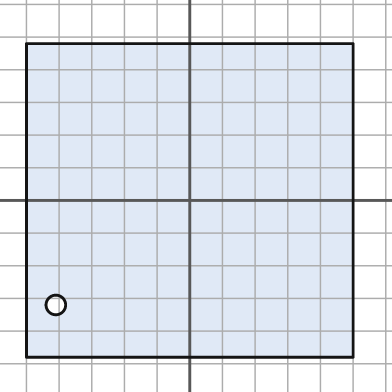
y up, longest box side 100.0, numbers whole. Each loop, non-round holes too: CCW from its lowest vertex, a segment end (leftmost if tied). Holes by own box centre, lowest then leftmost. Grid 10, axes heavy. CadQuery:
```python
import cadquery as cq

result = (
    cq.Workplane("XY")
    .moveTo(-50.0, -48.0)
    .lineTo(50.0, -48.0)
    .lineTo(50.0, 48.0)
    .lineTo(-50.0, 48.0)
    .close()
    .moveTo(-41.0, -32.0)
    .circle(3.0)
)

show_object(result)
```